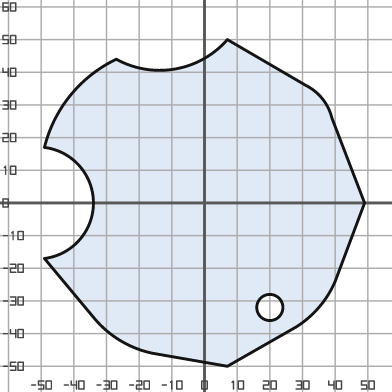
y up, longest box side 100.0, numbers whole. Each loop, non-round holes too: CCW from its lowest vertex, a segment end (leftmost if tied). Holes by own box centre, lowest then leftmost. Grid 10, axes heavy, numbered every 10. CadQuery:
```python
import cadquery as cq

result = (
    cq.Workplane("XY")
    .moveTo(7.0, -50.0)
    .lineTo(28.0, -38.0)
    .threePointArc((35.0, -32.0), (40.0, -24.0))
    .lineTo(49.0, 0.0)
    .lineTo(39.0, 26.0)
    .threePointArc((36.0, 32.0), (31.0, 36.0))
    .lineTo(7.0, 50.0)
    .threePointArc((-9.0, 41.0), (-27.0, 44.0))
    .threePointArc((-41.0, 33.0), (-49.0, 17.0))
    .threePointArc((-34.0, 0.0), (-49.0, -17.0))
    .lineTo(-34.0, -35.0)
    .threePointArc((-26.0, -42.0), (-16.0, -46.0))
    .close()
    .moveTo(20.0, -32.0)
    .circle(4.0)
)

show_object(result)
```